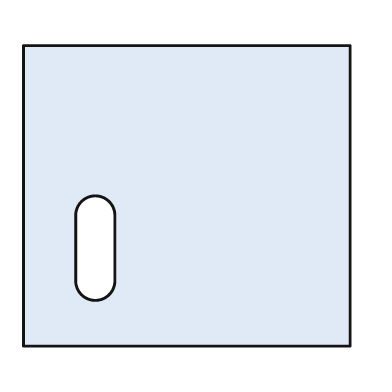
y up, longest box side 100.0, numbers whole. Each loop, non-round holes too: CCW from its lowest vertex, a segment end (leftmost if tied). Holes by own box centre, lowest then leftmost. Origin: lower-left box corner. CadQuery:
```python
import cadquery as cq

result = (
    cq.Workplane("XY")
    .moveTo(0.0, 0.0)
    .lineTo(100.0, 0.0)
    .lineTo(100.0, 92.0)
    .lineTo(0.0, 92.0)
    .close()
    .moveTo(16.0, 20.0)
    .threePointArc((22.0, 14.0), (28.0, 20.0))
    .lineTo(28.0, 40.0)
    .threePointArc((22.0, 46.0), (16.0, 40.0))
    .close()
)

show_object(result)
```